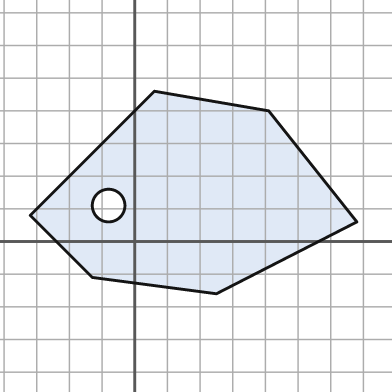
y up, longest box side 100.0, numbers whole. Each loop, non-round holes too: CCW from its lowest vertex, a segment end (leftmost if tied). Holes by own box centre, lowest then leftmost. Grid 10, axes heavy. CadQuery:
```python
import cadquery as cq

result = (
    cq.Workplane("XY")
    .moveTo(25.0, -16.0)
    .lineTo(68.0, 6.0)
    .lineTo(41.0, 40.0)
    .lineTo(6.0, 46.0)
    .lineTo(-32.0, 8.0)
    .lineTo(-13.0, -11.0)
    .close()
    .moveTo(-8.0, 11.0)
    .circle(5.0)
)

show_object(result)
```